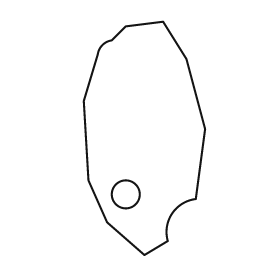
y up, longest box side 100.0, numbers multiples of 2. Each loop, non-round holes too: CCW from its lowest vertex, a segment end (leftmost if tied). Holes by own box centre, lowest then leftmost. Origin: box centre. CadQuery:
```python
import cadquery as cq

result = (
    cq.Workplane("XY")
    .moveTo(0.0, -50.0)
    .lineTo(10.0, -44.0)
    .threePointArc((12.0, -32.0), (22.0, -26.0))
    .lineTo(26.0, 4.0)
    .lineTo(18.0, 34.0)
    .lineTo(8.0, 50.0)
    .lineTo(-8.0, 48.0)
    .lineTo(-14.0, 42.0)
    .threePointArc((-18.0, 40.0), (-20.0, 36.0))
    .lineTo(-26.0, 16.0)
    .lineTo(-24.0, -18.0)
    .lineTo(-16.0, -36.0)
    .close()
    .moveTo(-8.0, -24.0)
    .circle(6.0)
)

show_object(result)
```